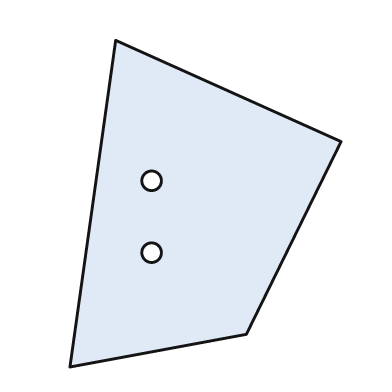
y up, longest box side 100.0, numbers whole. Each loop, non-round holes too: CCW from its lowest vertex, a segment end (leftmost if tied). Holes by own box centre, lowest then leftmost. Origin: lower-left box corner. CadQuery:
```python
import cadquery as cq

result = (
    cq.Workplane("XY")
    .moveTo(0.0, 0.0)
    .lineTo(54.0, 10.0)
    .lineTo(83.0, 69.0)
    .lineTo(14.0, 100.0)
    .close()
    .moveTo(25.0, 35.0)
    .circle(3.0)
    .moveTo(25.0, 57.0)
    .circle(3.0)
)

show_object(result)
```